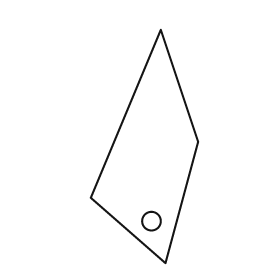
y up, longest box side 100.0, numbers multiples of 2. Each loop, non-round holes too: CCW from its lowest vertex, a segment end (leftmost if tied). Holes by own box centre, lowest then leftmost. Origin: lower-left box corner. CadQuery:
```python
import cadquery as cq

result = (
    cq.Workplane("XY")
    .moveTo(32.0, 0.0)
    .lineTo(46.0, 52.0)
    .lineTo(30.0, 100.0)
    .lineTo(0.0, 28.0)
    .close()
    .moveTo(26.0, 18.0)
    .circle(4.0)
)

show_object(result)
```